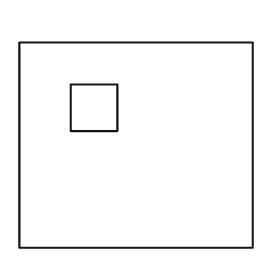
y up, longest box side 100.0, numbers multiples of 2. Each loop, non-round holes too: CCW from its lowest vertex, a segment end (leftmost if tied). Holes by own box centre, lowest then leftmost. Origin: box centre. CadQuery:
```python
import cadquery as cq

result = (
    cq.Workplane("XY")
    .moveTo(-50.0, -44.0)
    .lineTo(50.0, -44.0)
    .lineTo(50.0, 44.0)
    .lineTo(-50.0, 44.0)
    .close()
    .moveTo(-28.0, 6.0)
    .lineTo(-8.0, 6.0)
    .lineTo(-8.0, 26.0)
    .lineTo(-28.0, 26.0)
    .close()
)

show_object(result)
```